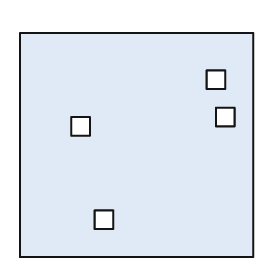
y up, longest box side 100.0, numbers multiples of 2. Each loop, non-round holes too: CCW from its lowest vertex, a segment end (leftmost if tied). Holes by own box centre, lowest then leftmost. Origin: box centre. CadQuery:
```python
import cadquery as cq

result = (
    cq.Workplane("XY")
    .moveTo(-50.0, -48.0)
    .lineTo(50.0, -48.0)
    .lineTo(50.0, 48.0)
    .lineTo(-50.0, 48.0)
    .close()
    .moveTo(-18.0, -36.0)
    .lineTo(-10.0, -36.0)
    .lineTo(-10.0, -28.0)
    .lineTo(-18.0, -28.0)
    .close()
    .moveTo(-28.0, 4.0)
    .lineTo(-20.0, 4.0)
    .lineTo(-20.0, 12.0)
    .lineTo(-28.0, 12.0)
    .close()
    .moveTo(34.0, 8.0)
    .lineTo(42.0, 8.0)
    .lineTo(42.0, 16.0)
    .lineTo(34.0, 16.0)
    .close()
    .moveTo(30.0, 24.0)
    .lineTo(38.0, 24.0)
    .lineTo(38.0, 32.0)
    .lineTo(30.0, 32.0)
    .close()
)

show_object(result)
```